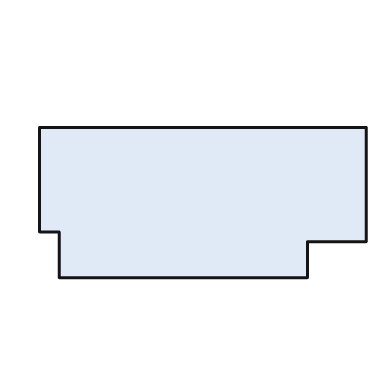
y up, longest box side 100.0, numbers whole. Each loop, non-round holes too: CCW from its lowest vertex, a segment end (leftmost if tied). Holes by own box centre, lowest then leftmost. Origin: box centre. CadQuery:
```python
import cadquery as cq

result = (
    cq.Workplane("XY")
    .moveTo(-44.0, -23.0)
    .lineTo(32.0, -23.0)
    .lineTo(32.0, -12.0)
    .lineTo(50.0, -12.0)
    .lineTo(50.0, 23.0)
    .lineTo(-50.0, 23.0)
    .lineTo(-50.0, -9.0)
    .lineTo(-44.0, -9.0)
    .close()
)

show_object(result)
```